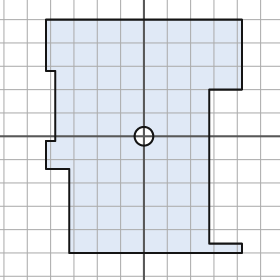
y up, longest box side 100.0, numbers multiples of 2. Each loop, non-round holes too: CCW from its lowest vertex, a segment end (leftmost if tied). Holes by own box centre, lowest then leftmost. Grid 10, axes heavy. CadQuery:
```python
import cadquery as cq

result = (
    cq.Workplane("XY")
    .moveTo(-32.0, -50.0)
    .lineTo(42.0, -50.0)
    .lineTo(42.0, -46.0)
    .lineTo(28.0, -46.0)
    .lineTo(28.0, 20.0)
    .lineTo(42.0, 20.0)
    .lineTo(42.0, 50.0)
    .lineTo(-42.0, 50.0)
    .lineTo(-42.0, 28.0)
    .lineTo(-38.0, 28.0)
    .lineTo(-38.0, -2.0)
    .lineTo(-42.0, -2.0)
    .lineTo(-42.0, -14.0)
    .lineTo(-32.0, -14.0)
    .close()
    .moveTo(0.0, 0.0)
    .circle(4.0)
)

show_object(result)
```